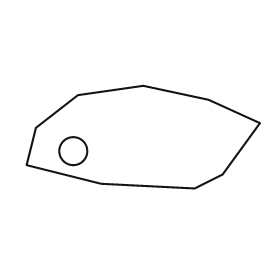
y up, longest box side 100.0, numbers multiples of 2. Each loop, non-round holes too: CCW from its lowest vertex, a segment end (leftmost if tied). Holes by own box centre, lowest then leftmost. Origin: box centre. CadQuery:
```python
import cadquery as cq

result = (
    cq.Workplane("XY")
    .moveTo(22.0, -22.0)
    .lineTo(34.0, -16.0)
    .lineTo(50.0, 6.0)
    .lineTo(28.0, 16.0)
    .lineTo(0.0, 22.0)
    .lineTo(-28.0, 18.0)
    .lineTo(-46.0, 4.0)
    .lineTo(-50.0, -12.0)
    .lineTo(-18.0, -20.0)
    .close()
    .moveTo(-30.0, -6.0)
    .circle(6.0)
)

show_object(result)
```